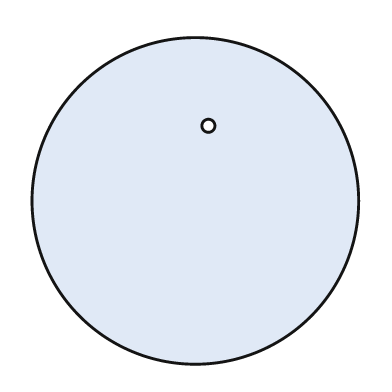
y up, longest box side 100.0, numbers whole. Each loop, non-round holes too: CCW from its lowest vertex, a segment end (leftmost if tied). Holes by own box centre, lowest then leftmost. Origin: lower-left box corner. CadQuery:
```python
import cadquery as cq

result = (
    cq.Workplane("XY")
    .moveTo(50.0, 50.0)
    .circle(50.0)
    .moveTo(54.0, 73.0)
    .circle(2.0)
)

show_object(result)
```